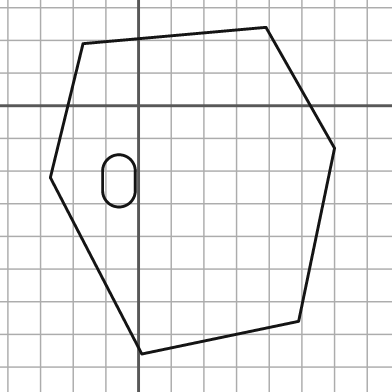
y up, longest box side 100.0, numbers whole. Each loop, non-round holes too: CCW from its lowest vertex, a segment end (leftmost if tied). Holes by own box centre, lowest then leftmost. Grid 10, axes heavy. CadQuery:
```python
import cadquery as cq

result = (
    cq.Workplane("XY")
    .moveTo(1.0, -76.0)
    .lineTo(49.0, -66.0)
    .lineTo(60.0, -13.0)
    .lineTo(39.0, 24.0)
    .lineTo(-17.0, 19.0)
    .lineTo(-27.0, -22.0)
    .close()
    .moveTo(-11.0, -26.0)
    .threePointArc((-6.0, -31.0), (-1.0, -26.0))
    .lineTo(-1.0, -20.0)
    .threePointArc((-6.0, -15.0), (-11.0, -20.0))
    .close()
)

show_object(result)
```